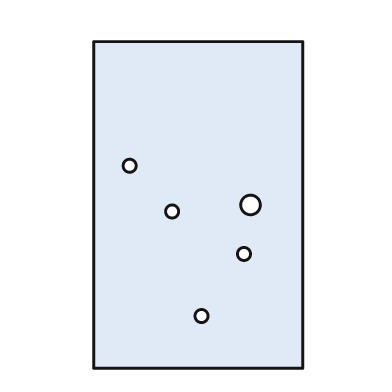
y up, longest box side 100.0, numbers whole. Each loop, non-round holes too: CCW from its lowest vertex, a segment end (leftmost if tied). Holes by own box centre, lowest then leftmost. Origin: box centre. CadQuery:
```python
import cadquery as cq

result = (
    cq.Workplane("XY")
    .moveTo(-32.0, -50.0)
    .lineTo(32.0, -50.0)
    .lineTo(32.0, 50.0)
    .lineTo(-32.0, 50.0)
    .close()
    .moveTo(1.0, -34.0)
    .circle(2.0)
    .moveTo(14.0, -15.0)
    .circle(2.0)
    .moveTo(-8.0, -2.0)
    .circle(2.0)
    .moveTo(16.0, 0.0)
    .circle(3.0)
    .moveTo(-21.0, 12.0)
    .circle(2.0)
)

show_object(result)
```